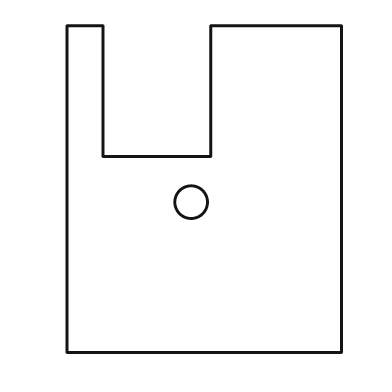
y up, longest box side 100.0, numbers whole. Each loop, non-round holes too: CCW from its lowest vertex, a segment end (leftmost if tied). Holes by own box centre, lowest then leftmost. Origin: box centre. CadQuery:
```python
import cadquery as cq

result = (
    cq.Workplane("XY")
    .moveTo(-42.0, -50.0)
    .lineTo(42.0, -50.0)
    .lineTo(42.0, 50.0)
    .lineTo(2.0, 50.0)
    .lineTo(2.0, 10.0)
    .lineTo(-31.0, 10.0)
    .lineTo(-31.0, 50.0)
    .lineTo(-42.0, 50.0)
    .close()
    .moveTo(-4.0, -4.0)
    .circle(5.0)
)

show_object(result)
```